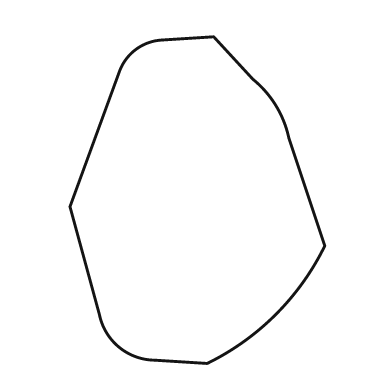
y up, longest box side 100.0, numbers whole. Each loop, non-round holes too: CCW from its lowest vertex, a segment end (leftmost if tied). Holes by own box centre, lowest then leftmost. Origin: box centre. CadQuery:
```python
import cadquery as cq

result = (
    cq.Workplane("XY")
    .moveTo(3.0, -50.0)
    .threePointArc((24.0, -35.0), (39.0, -14.0))
    .lineTo(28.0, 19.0)
    .threePointArc((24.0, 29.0), (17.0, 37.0))
    .lineTo(5.0, 50.0)
    .lineTo(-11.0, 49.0)
    .threePointArc((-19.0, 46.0), (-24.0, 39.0))
    .lineTo(-39.0, -2.0)
    .lineTo(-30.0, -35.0)
    .threePointArc((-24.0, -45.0), (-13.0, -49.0))
    .close()
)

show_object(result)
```